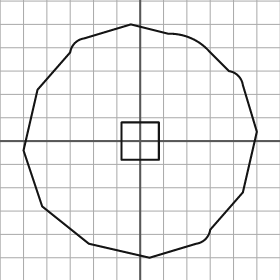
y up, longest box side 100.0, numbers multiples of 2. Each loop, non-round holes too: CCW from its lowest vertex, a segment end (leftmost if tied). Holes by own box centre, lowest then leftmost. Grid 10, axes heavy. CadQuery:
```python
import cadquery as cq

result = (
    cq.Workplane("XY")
    .moveTo(4.0, -50.0)
    .lineTo(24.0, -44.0)
    .threePointArc((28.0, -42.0), (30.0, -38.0))
    .lineTo(44.0, -22.0)
    .lineTo(50.0, 4.0)
    .lineTo(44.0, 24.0)
    .threePointArc((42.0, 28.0), (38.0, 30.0))
    .lineTo(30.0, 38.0)
    .threePointArc((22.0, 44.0), (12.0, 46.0))
    .lineTo(-4.0, 50.0)
    .lineTo(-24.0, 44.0)
    .threePointArc((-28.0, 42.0), (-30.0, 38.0))
    .lineTo(-44.0, 22.0)
    .lineTo(-50.0, -4.0)
    .lineTo(-42.0, -28.0)
    .lineTo(-22.0, -44.0)
    .close()
    .moveTo(-8.0, -8.0)
    .lineTo(8.0, -8.0)
    .lineTo(8.0, 8.0)
    .lineTo(-8.0, 8.0)
    .close()
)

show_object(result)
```